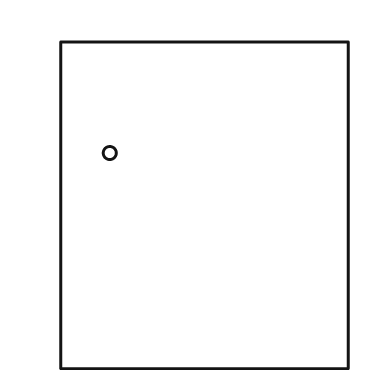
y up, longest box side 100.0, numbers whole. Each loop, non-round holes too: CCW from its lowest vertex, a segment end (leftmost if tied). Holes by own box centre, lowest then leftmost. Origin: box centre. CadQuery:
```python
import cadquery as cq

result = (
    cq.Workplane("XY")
    .moveTo(-44.0, -50.0)
    .lineTo(44.0, -50.0)
    .lineTo(44.0, 50.0)
    .lineTo(-44.0, 50.0)
    .close()
    .moveTo(-29.0, 16.0)
    .circle(2.0)
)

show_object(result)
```